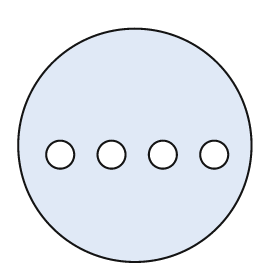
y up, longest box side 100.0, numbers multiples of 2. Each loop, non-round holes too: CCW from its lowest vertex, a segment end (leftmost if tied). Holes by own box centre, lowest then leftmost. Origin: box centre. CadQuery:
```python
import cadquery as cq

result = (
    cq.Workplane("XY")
    .moveTo(0.0, 0.0)
    .circle(50.0)
    .moveTo(-32.0, -4.0)
    .circle(6.0)
    .moveTo(-10.0, -4.0)
    .circle(6.0)
    .moveTo(12.0, -4.0)
    .circle(6.0)
    .moveTo(34.0, -4.0)
    .circle(6.0)
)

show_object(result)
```